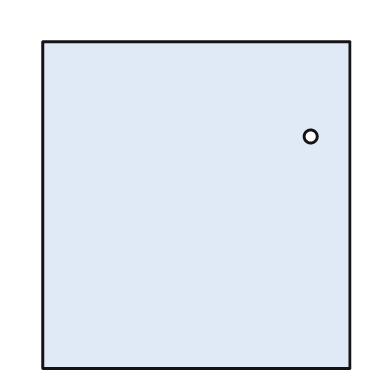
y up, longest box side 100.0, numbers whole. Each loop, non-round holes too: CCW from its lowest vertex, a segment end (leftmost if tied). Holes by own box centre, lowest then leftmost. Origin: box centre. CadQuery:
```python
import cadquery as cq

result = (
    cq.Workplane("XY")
    .moveTo(-47.0, -50.0)
    .lineTo(47.0, -50.0)
    .lineTo(47.0, 50.0)
    .lineTo(-47.0, 50.0)
    .close()
    .moveTo(35.0, 21.0)
    .circle(2.0)
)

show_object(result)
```